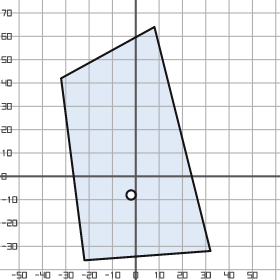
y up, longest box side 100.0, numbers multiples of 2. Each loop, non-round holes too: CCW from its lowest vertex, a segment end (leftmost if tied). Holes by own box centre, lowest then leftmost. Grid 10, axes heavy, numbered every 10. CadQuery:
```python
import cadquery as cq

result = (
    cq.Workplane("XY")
    .moveTo(-22.0, -36.0)
    .lineTo(32.0, -32.0)
    .lineTo(8.0, 64.0)
    .lineTo(-32.0, 42.0)
    .close()
    .moveTo(-2.0, -8.0)
    .circle(2.0)
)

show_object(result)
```